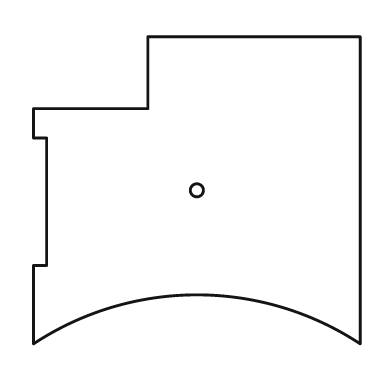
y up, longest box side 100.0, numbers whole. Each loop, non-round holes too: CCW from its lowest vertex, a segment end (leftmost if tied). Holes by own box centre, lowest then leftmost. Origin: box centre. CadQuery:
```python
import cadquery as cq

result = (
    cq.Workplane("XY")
    .moveTo(-50.0, -47.0)
    .threePointArc((0.0, -32.0), (50.0, -47.0))
    .lineTo(50.0, 47.0)
    .lineTo(-15.0, 47.0)
    .lineTo(-15.0, 25.0)
    .lineTo(-50.0, 25.0)
    .lineTo(-50.0, 16.0)
    .lineTo(-46.0, 16.0)
    .lineTo(-46.0, -23.0)
    .lineTo(-50.0, -23.0)
    .close()
    .moveTo(0.0, 0.0)
    .circle(2.0)
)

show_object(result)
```